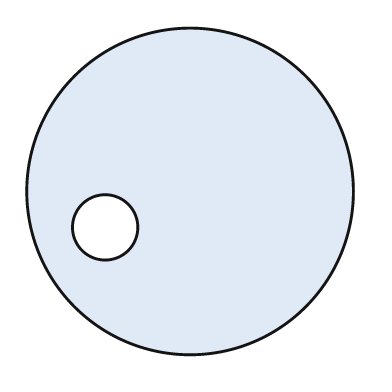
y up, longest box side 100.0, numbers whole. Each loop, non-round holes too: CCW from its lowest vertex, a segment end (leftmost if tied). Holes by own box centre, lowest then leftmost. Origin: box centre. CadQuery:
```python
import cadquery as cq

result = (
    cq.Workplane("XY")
    .moveTo(0.0, 0.0)
    .circle(50.0)
    .moveTo(-26.0, -11.0)
    .circle(10.0)
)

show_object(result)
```